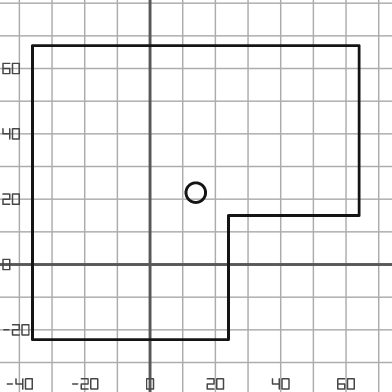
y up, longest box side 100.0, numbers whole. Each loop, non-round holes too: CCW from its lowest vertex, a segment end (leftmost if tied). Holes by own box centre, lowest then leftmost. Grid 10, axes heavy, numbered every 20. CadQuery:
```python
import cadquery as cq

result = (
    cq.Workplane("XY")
    .moveTo(-36.0, -23.0)
    .lineTo(24.0, -23.0)
    .lineTo(24.0, 15.0)
    .lineTo(64.0, 15.0)
    .lineTo(64.0, 67.0)
    .lineTo(-36.0, 67.0)
    .close()
    .moveTo(14.0, 22.0)
    .circle(3.0)
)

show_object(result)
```